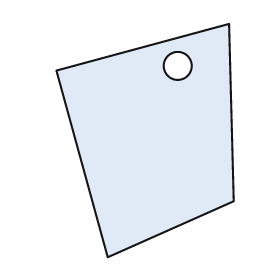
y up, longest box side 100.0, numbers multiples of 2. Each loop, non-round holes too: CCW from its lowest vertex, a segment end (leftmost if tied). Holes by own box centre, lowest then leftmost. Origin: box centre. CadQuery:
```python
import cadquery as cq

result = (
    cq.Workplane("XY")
    .moveTo(-16.0, -50.0)
    .lineTo(38.0, -26.0)
    .lineTo(36.0, 50.0)
    .lineTo(-38.0, 30.0)
    .close()
    .moveTo(14.0, 32.0)
    .circle(6.0)
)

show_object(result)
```